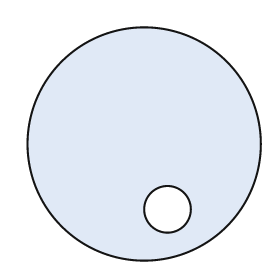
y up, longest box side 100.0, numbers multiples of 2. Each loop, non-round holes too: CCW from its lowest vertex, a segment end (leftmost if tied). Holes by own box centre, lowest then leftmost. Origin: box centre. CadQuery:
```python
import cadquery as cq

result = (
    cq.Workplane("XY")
    .moveTo(0.0, 0.0)
    .circle(50.0)
    .moveTo(10.0, -28.0)
    .circle(10.0)
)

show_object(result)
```